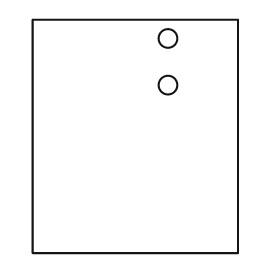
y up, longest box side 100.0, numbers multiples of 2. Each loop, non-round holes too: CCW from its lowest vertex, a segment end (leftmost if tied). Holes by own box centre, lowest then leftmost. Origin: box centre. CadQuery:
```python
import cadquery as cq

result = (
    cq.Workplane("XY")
    .moveTo(-44.0, -50.0)
    .lineTo(44.0, -50.0)
    .lineTo(44.0, 50.0)
    .lineTo(-44.0, 50.0)
    .close()
    .moveTo(14.0, 22.0)
    .circle(4.0)
    .moveTo(14.0, 42.0)
    .circle(4.0)
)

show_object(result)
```